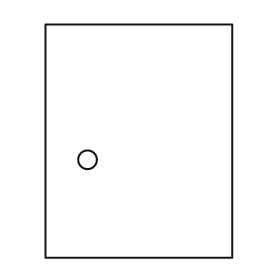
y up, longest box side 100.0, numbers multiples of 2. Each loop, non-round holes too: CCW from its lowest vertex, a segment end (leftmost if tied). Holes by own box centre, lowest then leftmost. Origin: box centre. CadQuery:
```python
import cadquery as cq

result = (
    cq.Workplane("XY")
    .moveTo(-40.0, -50.0)
    .lineTo(40.0, -50.0)
    .lineTo(40.0, 50.0)
    .lineTo(-40.0, 50.0)
    .close()
    .moveTo(-22.0, -8.0)
    .circle(4.0)
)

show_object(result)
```